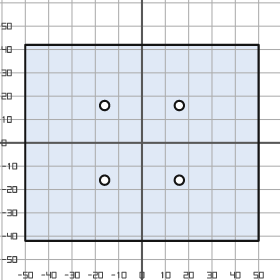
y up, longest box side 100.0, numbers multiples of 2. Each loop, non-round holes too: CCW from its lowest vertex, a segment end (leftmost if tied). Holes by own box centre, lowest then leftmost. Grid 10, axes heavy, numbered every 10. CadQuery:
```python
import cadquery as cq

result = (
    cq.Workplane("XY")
    .moveTo(-50.0, -42.0)
    .lineTo(50.0, -42.0)
    .lineTo(50.0, 42.0)
    .lineTo(-50.0, 42.0)
    .close()
    .moveTo(-16.0, -16.0)
    .circle(2.0)
    .moveTo(16.0, -16.0)
    .circle(2.0)
    .moveTo(-16.0, 16.0)
    .circle(2.0)
    .moveTo(16.0, 16.0)
    .circle(2.0)
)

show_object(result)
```